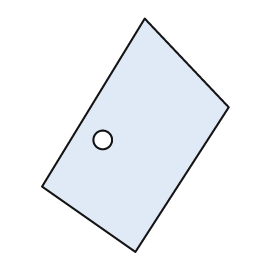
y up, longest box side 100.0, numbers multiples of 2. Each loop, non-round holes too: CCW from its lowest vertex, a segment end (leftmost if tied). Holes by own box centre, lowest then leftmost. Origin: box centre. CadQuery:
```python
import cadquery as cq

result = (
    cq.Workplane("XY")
    .moveTo(0.0, -50.0)
    .lineTo(40.0, 12.0)
    .lineTo(4.0, 50.0)
    .lineTo(-40.0, -22.0)
    .close()
    .moveTo(-14.0, -2.0)
    .circle(4.0)
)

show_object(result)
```